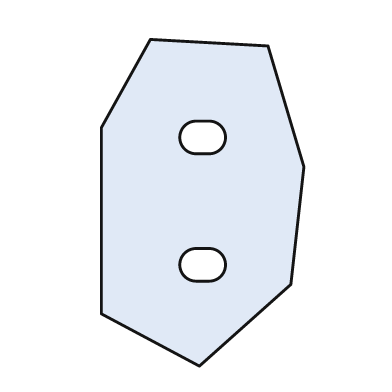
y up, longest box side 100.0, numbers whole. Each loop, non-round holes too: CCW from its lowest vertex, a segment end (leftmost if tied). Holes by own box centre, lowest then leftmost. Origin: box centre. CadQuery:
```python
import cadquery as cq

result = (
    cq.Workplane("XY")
    .moveTo(-1.0, -50.0)
    .lineTo(27.0, -25.0)
    .lineTo(31.0, 11.0)
    .lineTo(20.0, 48.0)
    .lineTo(-16.0, 50.0)
    .lineTo(-31.0, 23.0)
    .lineTo(-31.0, -34.0)
    .close()
    .moveTo(-2.0, -24.0)
    .lineTo(2.0, -24.0)
    .threePointArc((7.0, -19.0), (2.0, -14.0))
    .lineTo(-2.0, -14.0)
    .threePointArc((-7.0, -19.0), (-2.0, -24.0))
    .close()
    .moveTo(-2.0, 15.0)
    .lineTo(2.0, 15.0)
    .threePointArc((7.0, 20.0), (2.0, 25.0))
    .lineTo(-2.0, 25.0)
    .threePointArc((-7.0, 20.0), (-2.0, 15.0))
    .close()
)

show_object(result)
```